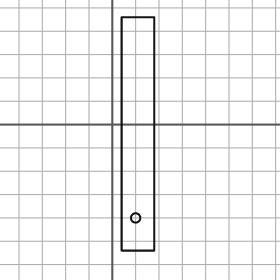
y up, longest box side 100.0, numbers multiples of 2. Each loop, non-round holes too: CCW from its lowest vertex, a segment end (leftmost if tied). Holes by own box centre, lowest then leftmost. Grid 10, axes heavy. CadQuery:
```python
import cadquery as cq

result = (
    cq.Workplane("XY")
    .moveTo(4.0, -54.0)
    .lineTo(18.0, -54.0)
    .lineTo(18.0, 46.0)
    .lineTo(4.0, 46.0)
    .close()
    .moveTo(10.0, -40.0)
    .circle(2.0)
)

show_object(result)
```